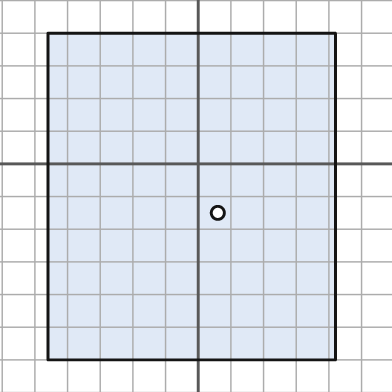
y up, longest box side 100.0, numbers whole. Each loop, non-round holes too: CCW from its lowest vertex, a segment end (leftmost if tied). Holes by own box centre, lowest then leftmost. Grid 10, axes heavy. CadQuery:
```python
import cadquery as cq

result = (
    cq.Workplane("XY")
    .moveTo(-46.0, -60.0)
    .lineTo(42.0, -60.0)
    .lineTo(42.0, 40.0)
    .lineTo(-46.0, 40.0)
    .close()
    .moveTo(6.0, -15.0)
    .circle(2.0)
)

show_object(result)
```